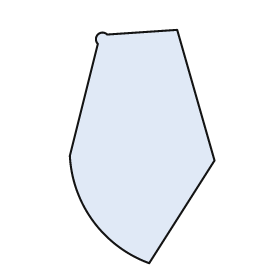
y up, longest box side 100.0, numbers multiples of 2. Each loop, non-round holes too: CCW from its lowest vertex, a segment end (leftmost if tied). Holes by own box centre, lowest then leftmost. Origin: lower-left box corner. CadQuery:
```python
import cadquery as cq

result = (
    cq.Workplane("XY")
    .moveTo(34.0, 0.0)
    .lineTo(62.0, 44.0)
    .lineTo(46.0, 100.0)
    .lineTo(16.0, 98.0)
    .threePointArc((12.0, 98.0), (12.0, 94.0))
    .lineTo(0.0, 46.0)
    .threePointArc((10.0, 18.0), (34.0, 0.0))
    .close()
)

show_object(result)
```